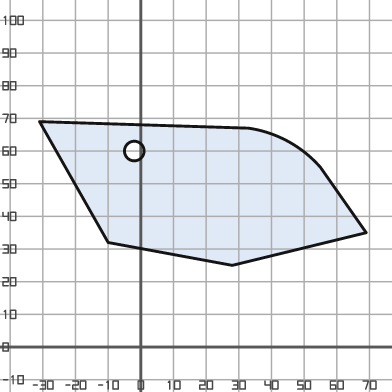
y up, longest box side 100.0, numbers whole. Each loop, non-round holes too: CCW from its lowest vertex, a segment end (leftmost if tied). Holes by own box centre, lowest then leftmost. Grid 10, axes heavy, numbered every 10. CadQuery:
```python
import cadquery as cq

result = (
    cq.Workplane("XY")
    .moveTo(28.0, 25.0)
    .lineTo(69.0, 35.0)
    .lineTo(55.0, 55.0)
    .threePointArc((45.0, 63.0), (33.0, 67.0))
    .lineTo(-31.0, 69.0)
    .lineTo(-10.0, 32.0)
    .close()
    .moveTo(-2.0, 60.0)
    .circle(3.0)
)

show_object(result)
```